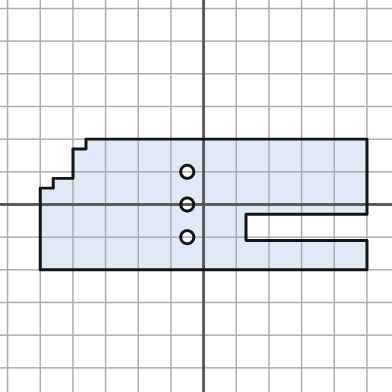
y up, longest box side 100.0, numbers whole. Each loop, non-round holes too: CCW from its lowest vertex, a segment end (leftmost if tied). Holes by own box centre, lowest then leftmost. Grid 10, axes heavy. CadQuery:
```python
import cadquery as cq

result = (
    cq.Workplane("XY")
    .moveTo(-50.0, -20.0)
    .lineTo(50.0, -20.0)
    .lineTo(50.0, -11.0)
    .lineTo(13.0, -11.0)
    .lineTo(13.0, -3.0)
    .lineTo(50.0, -3.0)
    .lineTo(50.0, 20.0)
    .lineTo(-36.0, 20.0)
    .lineTo(-36.0, 17.0)
    .lineTo(-40.0, 17.0)
    .lineTo(-40.0, 8.0)
    .lineTo(-46.0, 8.0)
    .lineTo(-46.0, 5.0)
    .lineTo(-50.0, 5.0)
    .close()
    .moveTo(-5.0, -10.0)
    .circle(2.0)
    .moveTo(-5.0, 0.0)
    .circle(2.0)
    .moveTo(-5.0, 10.0)
    .circle(2.0)
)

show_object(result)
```